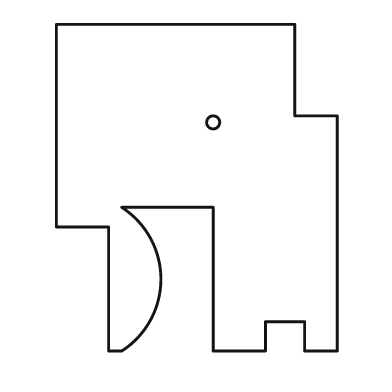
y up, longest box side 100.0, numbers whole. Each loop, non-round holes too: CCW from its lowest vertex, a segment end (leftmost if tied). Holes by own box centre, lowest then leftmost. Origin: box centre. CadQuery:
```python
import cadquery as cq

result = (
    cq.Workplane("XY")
    .moveTo(-27.0, -50.0)
    .lineTo(-23.0, -50.0)
    .threePointArc((-11.0, -28.0), (-23.0, -6.0))
    .lineTo(5.0, -6.0)
    .lineTo(5.0, -50.0)
    .lineTo(21.0, -50.0)
    .lineTo(21.0, -41.0)
    .lineTo(33.0, -41.0)
    .lineTo(33.0, -50.0)
    .lineTo(43.0, -50.0)
    .lineTo(43.0, 22.0)
    .lineTo(30.0, 22.0)
    .lineTo(30.0, 50.0)
    .lineTo(-43.0, 50.0)
    .lineTo(-43.0, -12.0)
    .lineTo(-27.0, -12.0)
    .close()
    .moveTo(5.0, 20.0)
    .circle(2.0)
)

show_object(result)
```